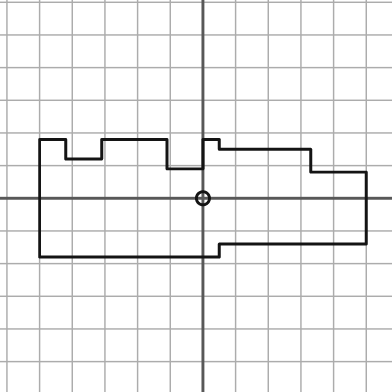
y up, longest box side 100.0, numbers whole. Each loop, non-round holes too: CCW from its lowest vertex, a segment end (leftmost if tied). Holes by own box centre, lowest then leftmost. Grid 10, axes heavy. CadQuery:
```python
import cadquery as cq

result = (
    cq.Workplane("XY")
    .moveTo(-50.0, -18.0)
    .lineTo(5.0, -18.0)
    .lineTo(5.0, -14.0)
    .lineTo(50.0, -14.0)
    .lineTo(50.0, 8.0)
    .lineTo(33.0, 8.0)
    .lineTo(33.0, 15.0)
    .lineTo(5.0, 15.0)
    .lineTo(5.0, 18.0)
    .lineTo(0.0, 18.0)
    .lineTo(0.0, 9.0)
    .lineTo(-11.0, 9.0)
    .lineTo(-11.0, 18.0)
    .lineTo(-31.0, 18.0)
    .lineTo(-31.0, 12.0)
    .lineTo(-42.0, 12.0)
    .lineTo(-42.0, 18.0)
    .lineTo(-50.0, 18.0)
    .close()
    .moveTo(0.0, 0.0)
    .circle(2.0)
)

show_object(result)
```